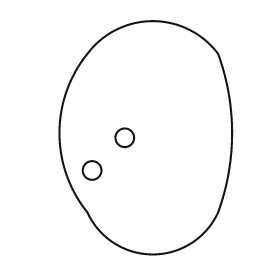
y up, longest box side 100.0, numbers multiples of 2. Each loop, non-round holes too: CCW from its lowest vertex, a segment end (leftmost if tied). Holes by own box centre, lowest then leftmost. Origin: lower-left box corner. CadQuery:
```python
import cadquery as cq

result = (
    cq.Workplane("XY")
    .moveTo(12.0, 18.0)
    .threePointArc((40.0, 0.0), (68.0, 18.0))
    .threePointArc((74.0, 52.0), (68.0, 86.0))
    .threePointArc((40.0, 100.0), (12.0, 86.0))
    .threePointArc((0.0, 52.0), (12.0, 18.0))
    .close()
    .moveTo(14.0, 36.0)
    .circle(4.0)
    .moveTo(28.0, 50.0)
    .circle(4.0)
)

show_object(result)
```